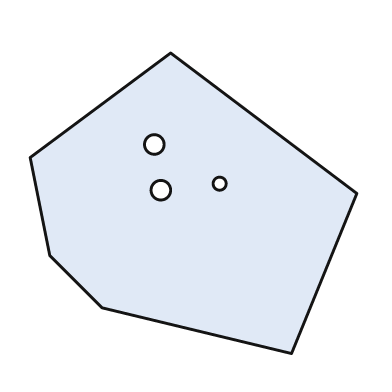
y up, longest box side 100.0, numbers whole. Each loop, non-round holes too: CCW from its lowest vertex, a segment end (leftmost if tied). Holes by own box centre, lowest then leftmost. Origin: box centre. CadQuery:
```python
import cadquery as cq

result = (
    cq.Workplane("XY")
    .moveTo(30.0, -46.0)
    .lineTo(50.0, 3.0)
    .lineTo(-7.0, 46.0)
    .lineTo(-50.0, 14.0)
    .lineTo(-44.0, -16.0)
    .lineTo(-28.0, -32.0)
    .close()
    .moveTo(-10.0, 4.0)
    .circle(3.0)
    .moveTo(8.0, 6.0)
    .circle(2.0)
    .moveTo(-12.0, 18.0)
    .circle(3.0)
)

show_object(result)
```